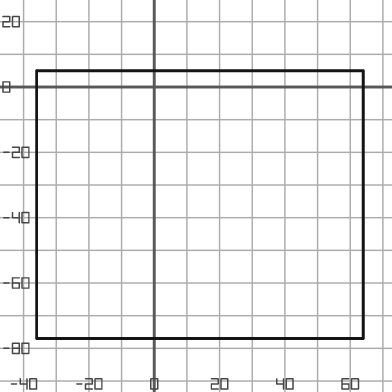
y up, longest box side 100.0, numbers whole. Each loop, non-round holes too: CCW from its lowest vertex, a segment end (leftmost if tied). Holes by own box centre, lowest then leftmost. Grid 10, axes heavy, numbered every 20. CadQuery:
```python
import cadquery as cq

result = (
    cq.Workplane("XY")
    .moveTo(-36.0, -77.0)
    .lineTo(64.0, -77.0)
    .lineTo(64.0, 5.0)
    .lineTo(-36.0, 5.0)
    .close()
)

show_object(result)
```